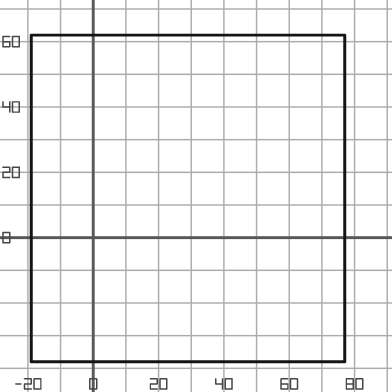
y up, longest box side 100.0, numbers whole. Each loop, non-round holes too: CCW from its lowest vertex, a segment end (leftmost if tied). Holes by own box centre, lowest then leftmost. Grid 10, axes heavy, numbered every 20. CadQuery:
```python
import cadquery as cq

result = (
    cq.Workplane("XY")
    .moveTo(-19.0, -38.0)
    .lineTo(77.0, -38.0)
    .lineTo(77.0, 62.0)
    .lineTo(-19.0, 62.0)
    .close()
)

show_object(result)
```